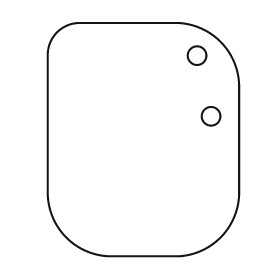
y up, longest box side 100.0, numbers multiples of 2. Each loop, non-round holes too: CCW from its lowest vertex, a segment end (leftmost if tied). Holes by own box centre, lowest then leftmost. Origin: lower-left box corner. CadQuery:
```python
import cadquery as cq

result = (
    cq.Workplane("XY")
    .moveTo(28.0, 0.0)
    .lineTo(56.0, 0.0)
    .threePointArc((74.0, 8.0), (82.0, 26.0))
    .lineTo(82.0, 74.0)
    .threePointArc((74.0, 92.0), (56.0, 100.0))
    .lineTo(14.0, 100.0)
    .threePointArc((4.0, 96.0), (0.0, 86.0))
    .lineTo(0.0, 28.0)
    .threePointArc((8.0, 8.0), (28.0, 0.0))
    .close()
    .moveTo(70.0, 60.0)
    .circle(4.0)
    .moveTo(64.0, 86.0)
    .circle(4.0)
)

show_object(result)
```